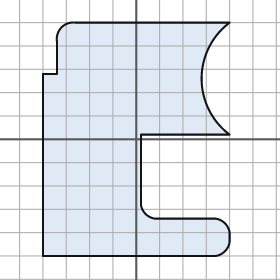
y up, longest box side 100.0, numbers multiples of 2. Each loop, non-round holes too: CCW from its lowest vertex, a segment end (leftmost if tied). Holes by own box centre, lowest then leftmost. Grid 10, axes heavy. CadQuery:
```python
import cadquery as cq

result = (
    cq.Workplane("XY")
    .moveTo(-40.0, -50.0)
    .lineTo(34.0, -50.0)
    .threePointArc((38.0, -48.0), (40.0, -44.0))
    .lineTo(40.0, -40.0)
    .threePointArc((38.0, -36.0), (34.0, -34.0))
    .lineTo(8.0, -34.0)
    .threePointArc((4.0, -32.0), (2.0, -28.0))
    .lineTo(2.0, 2.0)
    .lineTo(40.0, 2.0)
    .threePointArc((28.0, 26.0), (40.0, 50.0))
    .lineTo(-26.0, 50.0)
    .threePointArc((-32.0, 48.0), (-34.0, 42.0))
    .lineTo(-34.0, 28.0)
    .lineTo(-40.0, 28.0)
    .close()
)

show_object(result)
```